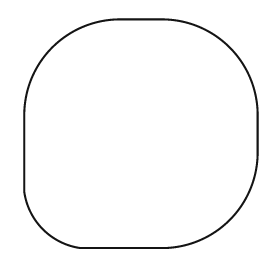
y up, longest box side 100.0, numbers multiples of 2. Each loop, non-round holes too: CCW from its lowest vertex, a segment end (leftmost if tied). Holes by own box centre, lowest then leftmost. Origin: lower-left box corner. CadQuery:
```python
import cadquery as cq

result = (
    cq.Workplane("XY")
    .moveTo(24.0, 0.0)
    .lineTo(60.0, 0.0)
    .threePointArc((88.0, 12.0), (100.0, 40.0))
    .lineTo(100.0, 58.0)
    .threePointArc((88.0, 86.0), (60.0, 98.0))
    .lineTo(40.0, 98.0)
    .threePointArc((12.0, 86.0), (0.0, 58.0))
    .lineTo(0.0, 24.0)
    .threePointArc((8.0, 8.0), (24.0, 0.0))
    .close()
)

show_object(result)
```